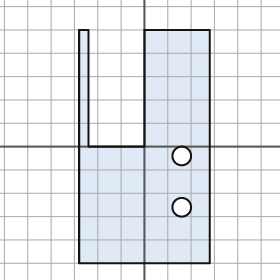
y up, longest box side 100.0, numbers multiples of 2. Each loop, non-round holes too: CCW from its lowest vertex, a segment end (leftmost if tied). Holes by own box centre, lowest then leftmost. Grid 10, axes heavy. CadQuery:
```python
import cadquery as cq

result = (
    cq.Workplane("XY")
    .moveTo(-28.0, -50.0)
    .lineTo(28.0, -50.0)
    .lineTo(28.0, 50.0)
    .lineTo(0.0, 50.0)
    .lineTo(0.0, 0.0)
    .lineTo(-24.0, 0.0)
    .lineTo(-24.0, 50.0)
    .lineTo(-28.0, 50.0)
    .close()
    .moveTo(16.0, -26.0)
    .circle(4.0)
    .moveTo(16.0, -4.0)
    .circle(4.0)
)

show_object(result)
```